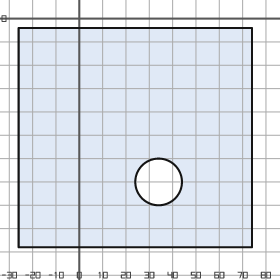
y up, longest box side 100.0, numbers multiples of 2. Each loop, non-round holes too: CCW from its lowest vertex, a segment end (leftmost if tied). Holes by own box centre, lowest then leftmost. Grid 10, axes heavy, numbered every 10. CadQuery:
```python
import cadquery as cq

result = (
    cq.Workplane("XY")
    .moveTo(-26.0, -98.0)
    .lineTo(74.0, -98.0)
    .lineTo(74.0, -4.0)
    .lineTo(-26.0, -4.0)
    .close()
    .moveTo(34.0, -70.0)
    .circle(10.0)
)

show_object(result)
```